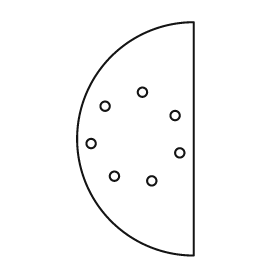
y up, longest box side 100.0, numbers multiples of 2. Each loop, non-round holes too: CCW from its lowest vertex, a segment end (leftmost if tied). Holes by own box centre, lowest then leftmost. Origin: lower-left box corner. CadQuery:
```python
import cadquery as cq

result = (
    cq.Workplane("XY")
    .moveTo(50.0, 0.0)
    .lineTo(50.0, 100.0)
    .threePointArc((0.0, 50.0), (50.0, 0.0))
    .close()
    .moveTo(32.0, 32.0)
    .circle(2.0)
    .moveTo(16.0, 34.0)
    .circle(2.0)
    .moveTo(44.0, 44.0)
    .circle(2.0)
    .moveTo(6.0, 48.0)
    .circle(2.0)
    .moveTo(42.0, 60.0)
    .circle(2.0)
    .moveTo(12.0, 64.0)
    .circle(2.0)
    .moveTo(28.0, 70.0)
    .circle(2.0)
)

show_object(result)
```